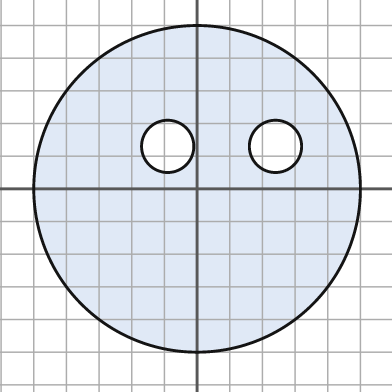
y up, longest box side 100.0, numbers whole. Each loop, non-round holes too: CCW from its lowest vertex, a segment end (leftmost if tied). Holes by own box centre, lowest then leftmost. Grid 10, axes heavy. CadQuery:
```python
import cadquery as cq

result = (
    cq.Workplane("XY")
    .moveTo(0.0, 0.0)
    .circle(50.0)
    .moveTo(-9.0, 13.0)
    .circle(8.0)
    .moveTo(24.0, 13.0)
    .circle(8.0)
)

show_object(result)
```